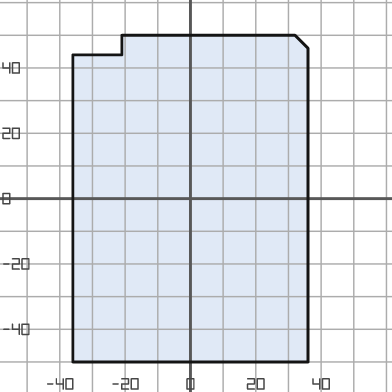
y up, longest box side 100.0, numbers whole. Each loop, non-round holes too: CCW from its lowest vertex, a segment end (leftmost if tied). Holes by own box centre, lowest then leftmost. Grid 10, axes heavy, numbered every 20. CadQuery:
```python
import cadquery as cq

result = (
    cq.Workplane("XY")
    .moveTo(-36.0, -50.0)
    .lineTo(36.0, -50.0)
    .lineTo(36.0, 46.0)
    .lineTo(32.0, 50.0)
    .lineTo(-21.0, 50.0)
    .lineTo(-21.0, 44.0)
    .lineTo(-36.0, 44.0)
    .close()
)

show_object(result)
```